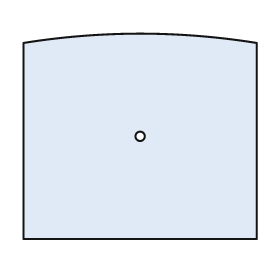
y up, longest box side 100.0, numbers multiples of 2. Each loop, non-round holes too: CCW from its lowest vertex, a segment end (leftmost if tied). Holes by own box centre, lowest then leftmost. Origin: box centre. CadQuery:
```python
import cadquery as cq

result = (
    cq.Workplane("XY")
    .moveTo(-50.0, -44.0)
    .lineTo(50.0, -44.0)
    .lineTo(50.0, 40.0)
    .threePointArc((0.0, 44.0), (-50.0, 40.0))
    .close()
    .moveTo(0.0, 0.0)
    .circle(2.0)
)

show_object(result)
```